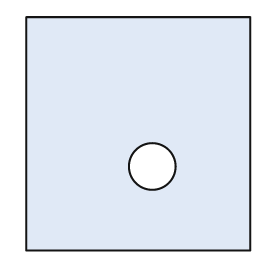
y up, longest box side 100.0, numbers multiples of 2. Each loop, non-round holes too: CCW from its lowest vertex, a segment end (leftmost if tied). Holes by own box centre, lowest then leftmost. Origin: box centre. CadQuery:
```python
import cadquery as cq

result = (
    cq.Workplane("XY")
    .moveTo(-48.0, -50.0)
    .lineTo(48.0, -50.0)
    .lineTo(48.0, 50.0)
    .lineTo(-48.0, 50.0)
    .close()
    .moveTo(6.0, -14.0)
    .circle(10.0)
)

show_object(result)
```